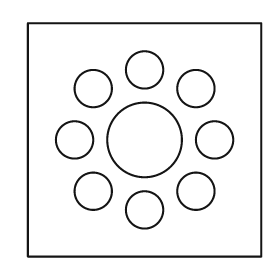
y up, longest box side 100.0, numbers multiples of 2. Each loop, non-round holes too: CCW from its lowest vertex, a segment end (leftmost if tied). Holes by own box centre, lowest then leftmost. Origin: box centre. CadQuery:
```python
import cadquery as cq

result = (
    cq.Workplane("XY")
    .moveTo(-50.0, -50.0)
    .lineTo(50.0, -50.0)
    .lineTo(50.0, 50.0)
    .lineTo(-50.0, 50.0)
    .close()
    .moveTo(0.0, -30.0)
    .circle(8.0)
    .moveTo(-22.0, -22.0)
    .circle(8.0)
    .moveTo(22.0, -22.0)
    .circle(8.0)
    .moveTo(-30.0, 0.0)
    .circle(8.0)
    .moveTo(0.0, 0.0)
    .circle(16.0)
    .moveTo(30.0, 0.0)
    .circle(8.0)
    .moveTo(-22.0, 22.0)
    .circle(8.0)
    .moveTo(22.0, 22.0)
    .circle(8.0)
    .moveTo(0.0, 30.0)
    .circle(8.0)
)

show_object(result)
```